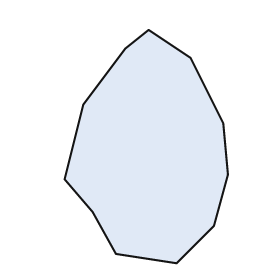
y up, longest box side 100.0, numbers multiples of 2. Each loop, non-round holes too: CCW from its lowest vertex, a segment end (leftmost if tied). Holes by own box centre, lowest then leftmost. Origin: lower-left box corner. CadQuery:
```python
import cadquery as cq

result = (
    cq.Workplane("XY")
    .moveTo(48.0, 0.0)
    .lineTo(64.0, 16.0)
    .lineTo(70.0, 38.0)
    .lineTo(68.0, 60.0)
    .lineTo(54.0, 88.0)
    .lineTo(36.0, 100.0)
    .lineTo(26.0, 92.0)
    .lineTo(8.0, 68.0)
    .lineTo(0.0, 36.0)
    .lineTo(12.0, 22.0)
    .lineTo(22.0, 4.0)
    .close()
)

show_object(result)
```